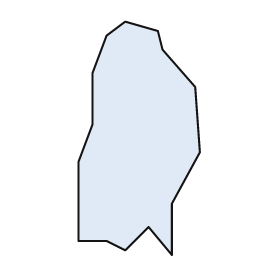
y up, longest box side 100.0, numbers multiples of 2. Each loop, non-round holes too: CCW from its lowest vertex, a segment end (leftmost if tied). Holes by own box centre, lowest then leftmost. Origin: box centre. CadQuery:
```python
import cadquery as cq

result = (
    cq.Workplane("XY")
    .moveTo(14.0, -50.0)
    .lineTo(14.0, -28.0)
    .lineTo(26.0, -6.0)
    .lineTo(24.0, 22.0)
    .lineTo(10.0, 38.0)
    .lineTo(8.0, 46.0)
    .lineTo(-6.0, 50.0)
    .lineTo(-14.0, 44.0)
    .lineTo(-20.0, 28.0)
    .lineTo(-20.0, 6.0)
    .lineTo(-26.0, -10.0)
    .lineTo(-26.0, -44.0)
    .lineTo(-14.0, -44.0)
    .lineTo(-6.0, -48.0)
    .lineTo(4.0, -38.0)
    .close()
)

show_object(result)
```